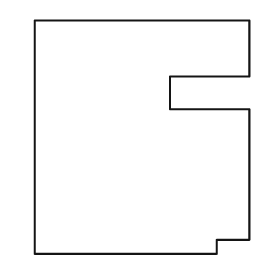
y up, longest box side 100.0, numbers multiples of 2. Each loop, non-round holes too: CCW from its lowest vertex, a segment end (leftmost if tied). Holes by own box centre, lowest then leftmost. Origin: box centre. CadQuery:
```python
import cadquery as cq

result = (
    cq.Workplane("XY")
    .moveTo(-46.0, -50.0)
    .lineTo(32.0, -50.0)
    .lineTo(32.0, -44.0)
    .lineTo(46.0, -44.0)
    .lineTo(46.0, 12.0)
    .lineTo(12.0, 12.0)
    .lineTo(12.0, 26.0)
    .lineTo(46.0, 26.0)
    .lineTo(46.0, 50.0)
    .lineTo(-46.0, 50.0)
    .close()
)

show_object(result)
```